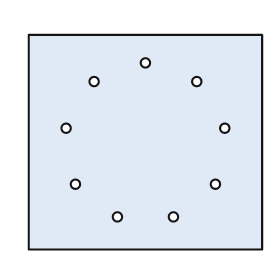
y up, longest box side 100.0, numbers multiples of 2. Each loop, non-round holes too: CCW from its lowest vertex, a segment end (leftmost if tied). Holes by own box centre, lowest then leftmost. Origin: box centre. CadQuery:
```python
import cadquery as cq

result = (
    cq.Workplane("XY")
    .moveTo(-50.0, -46.0)
    .lineTo(50.0, -46.0)
    .lineTo(50.0, 46.0)
    .lineTo(-50.0, 46.0)
    .close()
    .moveTo(-12.0, -32.0)
    .circle(2.0)
    .moveTo(12.0, -32.0)
    .circle(2.0)
    .moveTo(-30.0, -18.0)
    .circle(2.0)
    .moveTo(30.0, -18.0)
    .circle(2.0)
    .moveTo(-34.0, 6.0)
    .circle(2.0)
    .moveTo(34.0, 6.0)
    .circle(2.0)
    .moveTo(-22.0, 26.0)
    .circle(2.0)
    .moveTo(22.0, 26.0)
    .circle(2.0)
    .moveTo(0.0, 34.0)
    .circle(2.0)
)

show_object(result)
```